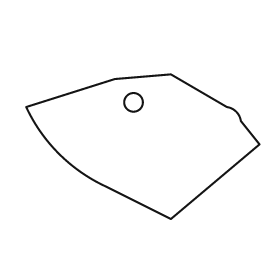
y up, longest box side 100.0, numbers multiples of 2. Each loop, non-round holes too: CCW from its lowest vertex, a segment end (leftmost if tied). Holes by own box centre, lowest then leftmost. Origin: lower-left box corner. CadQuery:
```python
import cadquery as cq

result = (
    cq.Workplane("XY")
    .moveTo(62.0, 0.0)
    .lineTo(100.0, 32.0)
    .lineTo(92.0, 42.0)
    .threePointArc((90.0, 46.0), (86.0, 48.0))
    .lineTo(62.0, 62.0)
    .lineTo(38.0, 60.0)
    .lineTo(0.0, 48.0)
    .threePointArc((14.0, 28.0), (34.0, 14.0))
    .close()
    .moveTo(46.0, 50.0)
    .circle(4.0)
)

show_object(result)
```